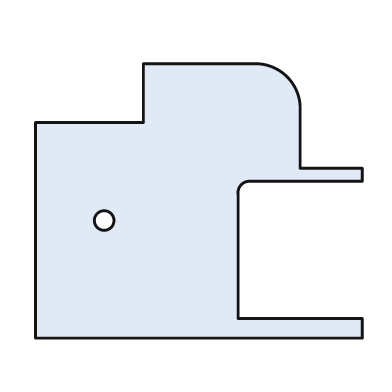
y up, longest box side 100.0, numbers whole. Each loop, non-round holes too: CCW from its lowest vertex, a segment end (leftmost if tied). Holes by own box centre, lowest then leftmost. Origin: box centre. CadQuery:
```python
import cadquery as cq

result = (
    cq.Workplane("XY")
    .moveTo(-50.0, -42.0)
    .lineTo(50.0, -42.0)
    .lineTo(50.0, -36.0)
    .lineTo(12.0, -36.0)
    .lineTo(12.0, 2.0)
    .threePointArc((13.0, 5.0), (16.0, 6.0))
    .lineTo(50.0, 6.0)
    .lineTo(50.0, 10.0)
    .lineTo(31.0, 10.0)
    .lineTo(31.0, 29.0)
    .threePointArc((27.0, 38.0), (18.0, 42.0))
    .lineTo(-17.0, 42.0)
    .lineTo(-17.0, 24.0)
    .lineTo(-50.0, 24.0)
    .close()
    .moveTo(-29.0, -6.0)
    .circle(3.0)
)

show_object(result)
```